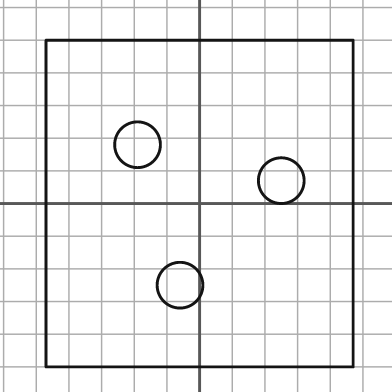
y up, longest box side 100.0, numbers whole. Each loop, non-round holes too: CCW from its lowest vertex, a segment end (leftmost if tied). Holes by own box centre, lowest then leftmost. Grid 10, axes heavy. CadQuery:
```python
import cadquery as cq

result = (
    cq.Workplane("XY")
    .moveTo(-47.0, -50.0)
    .lineTo(47.0, -50.0)
    .lineTo(47.0, 50.0)
    .lineTo(-47.0, 50.0)
    .close()
    .moveTo(-6.0, -25.0)
    .circle(7.0)
    .moveTo(25.0, 7.0)
    .circle(7.0)
    .moveTo(-19.0, 18.0)
    .circle(7.0)
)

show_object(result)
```